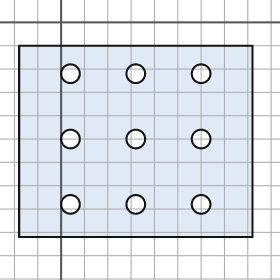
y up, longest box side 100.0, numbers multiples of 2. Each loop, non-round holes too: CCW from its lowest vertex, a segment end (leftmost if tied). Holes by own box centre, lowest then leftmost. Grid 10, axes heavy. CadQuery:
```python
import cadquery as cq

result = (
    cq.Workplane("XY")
    .moveTo(-18.0, -92.0)
    .lineTo(82.0, -92.0)
    .lineTo(82.0, -10.0)
    .lineTo(-18.0, -10.0)
    .close()
    .moveTo(4.0, -78.0)
    .circle(4.0)
    .moveTo(32.0, -78.0)
    .circle(4.0)
    .moveTo(60.0, -78.0)
    .circle(4.0)
    .moveTo(4.0, -50.0)
    .circle(4.0)
    .moveTo(32.0, -50.0)
    .circle(4.0)
    .moveTo(60.0, -50.0)
    .circle(4.0)
    .moveTo(4.0, -22.0)
    .circle(4.0)
    .moveTo(32.0, -22.0)
    .circle(4.0)
    .moveTo(60.0, -22.0)
    .circle(4.0)
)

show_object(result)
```